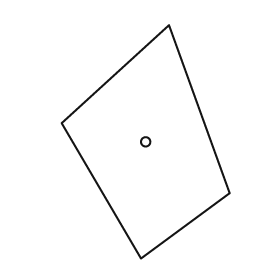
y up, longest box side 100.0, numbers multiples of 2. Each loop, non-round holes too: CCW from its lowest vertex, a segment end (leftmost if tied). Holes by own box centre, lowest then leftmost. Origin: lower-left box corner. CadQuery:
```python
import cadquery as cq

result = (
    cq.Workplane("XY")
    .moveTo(34.0, 0.0)
    .lineTo(72.0, 28.0)
    .lineTo(46.0, 100.0)
    .lineTo(0.0, 58.0)
    .close()
    .moveTo(36.0, 50.0)
    .circle(2.0)
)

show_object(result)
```